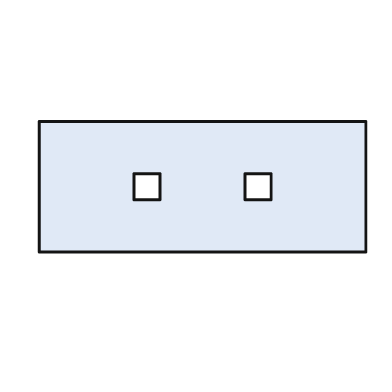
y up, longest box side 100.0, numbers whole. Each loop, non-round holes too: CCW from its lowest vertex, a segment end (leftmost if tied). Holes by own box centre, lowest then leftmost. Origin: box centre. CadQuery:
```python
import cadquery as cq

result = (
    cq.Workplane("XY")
    .moveTo(-50.0, -20.0)
    .lineTo(50.0, -20.0)
    .lineTo(50.0, 20.0)
    .lineTo(-50.0, 20.0)
    .close()
    .moveTo(-21.0, -4.0)
    .lineTo(-13.0, -4.0)
    .lineTo(-13.0, 4.0)
    .lineTo(-21.0, 4.0)
    .close()
    .moveTo(13.0, -4.0)
    .lineTo(21.0, -4.0)
    .lineTo(21.0, 4.0)
    .lineTo(13.0, 4.0)
    .close()
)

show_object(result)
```